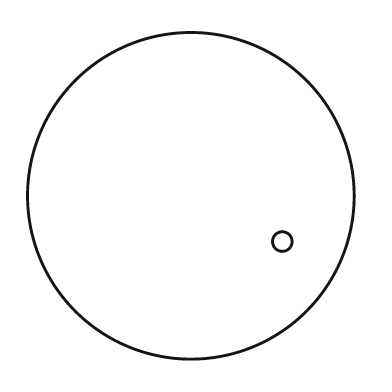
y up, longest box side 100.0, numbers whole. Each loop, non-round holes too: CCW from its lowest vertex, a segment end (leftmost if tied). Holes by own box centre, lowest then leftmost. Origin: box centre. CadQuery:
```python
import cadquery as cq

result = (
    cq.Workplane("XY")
    .moveTo(0.0, 0.0)
    .circle(50.0)
    .moveTo(28.0, -14.0)
    .circle(3.0)
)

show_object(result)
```